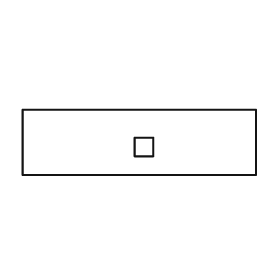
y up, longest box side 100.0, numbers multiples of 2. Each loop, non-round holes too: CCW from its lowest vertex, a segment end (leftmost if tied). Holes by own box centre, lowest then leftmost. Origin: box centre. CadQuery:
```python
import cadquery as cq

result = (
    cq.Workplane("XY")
    .moveTo(-50.0, -14.0)
    .lineTo(50.0, -14.0)
    .lineTo(50.0, 14.0)
    .lineTo(-50.0, 14.0)
    .close()
    .moveTo(-2.0, -6.0)
    .lineTo(6.0, -6.0)
    .lineTo(6.0, 2.0)
    .lineTo(-2.0, 2.0)
    .close()
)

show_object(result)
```